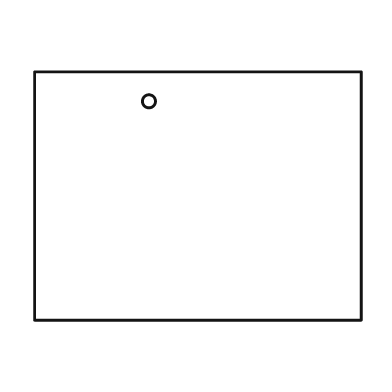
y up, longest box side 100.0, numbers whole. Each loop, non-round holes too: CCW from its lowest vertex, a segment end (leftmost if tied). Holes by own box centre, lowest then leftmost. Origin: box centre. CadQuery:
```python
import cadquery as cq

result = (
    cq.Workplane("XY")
    .moveTo(-50.0, -38.0)
    .lineTo(50.0, -38.0)
    .lineTo(50.0, 38.0)
    .lineTo(-50.0, 38.0)
    .close()
    .moveTo(-15.0, 29.0)
    .circle(2.0)
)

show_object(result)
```